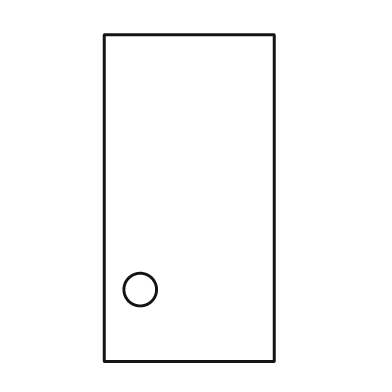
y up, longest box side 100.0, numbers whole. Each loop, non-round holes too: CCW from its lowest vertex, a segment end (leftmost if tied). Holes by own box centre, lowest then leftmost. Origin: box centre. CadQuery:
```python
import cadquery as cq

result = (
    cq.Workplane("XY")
    .moveTo(-26.0, -50.0)
    .lineTo(26.0, -50.0)
    .lineTo(26.0, 50.0)
    .lineTo(-26.0, 50.0)
    .close()
    .moveTo(-15.0, -28.0)
    .circle(5.0)
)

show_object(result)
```